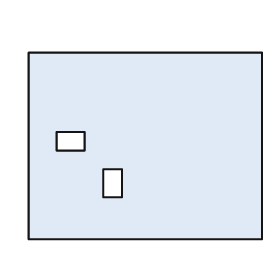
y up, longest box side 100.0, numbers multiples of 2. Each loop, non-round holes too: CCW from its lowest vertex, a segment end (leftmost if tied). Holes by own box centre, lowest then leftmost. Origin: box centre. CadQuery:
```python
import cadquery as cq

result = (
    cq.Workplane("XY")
    .moveTo(-50.0, -40.0)
    .lineTo(50.0, -40.0)
    .lineTo(50.0, 40.0)
    .lineTo(-50.0, 40.0)
    .close()
    .moveTo(-18.0, -22.0)
    .lineTo(-10.0, -22.0)
    .lineTo(-10.0, -10.0)
    .lineTo(-18.0, -10.0)
    .close()
    .moveTo(-38.0, -2.0)
    .lineTo(-26.0, -2.0)
    .lineTo(-26.0, 6.0)
    .lineTo(-38.0, 6.0)
    .close()
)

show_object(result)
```